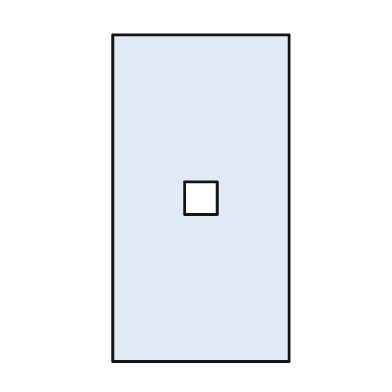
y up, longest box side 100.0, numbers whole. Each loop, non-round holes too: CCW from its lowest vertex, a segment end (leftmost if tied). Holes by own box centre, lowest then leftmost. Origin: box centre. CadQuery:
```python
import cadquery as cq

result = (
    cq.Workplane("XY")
    .moveTo(-27.0, -50.0)
    .lineTo(27.0, -50.0)
    .lineTo(27.0, 50.0)
    .lineTo(-27.0, 50.0)
    .close()
    .moveTo(-5.0, -5.0)
    .lineTo(5.0, -5.0)
    .lineTo(5.0, 5.0)
    .lineTo(-5.0, 5.0)
    .close()
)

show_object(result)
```